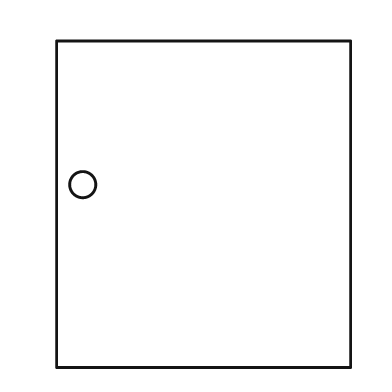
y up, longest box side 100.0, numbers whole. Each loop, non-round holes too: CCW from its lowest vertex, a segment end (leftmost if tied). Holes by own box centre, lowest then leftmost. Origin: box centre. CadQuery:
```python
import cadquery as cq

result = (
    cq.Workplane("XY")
    .moveTo(-45.0, -50.0)
    .lineTo(45.0, -50.0)
    .lineTo(45.0, 50.0)
    .lineTo(-45.0, 50.0)
    .close()
    .moveTo(-37.0, 6.0)
    .circle(4.0)
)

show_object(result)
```